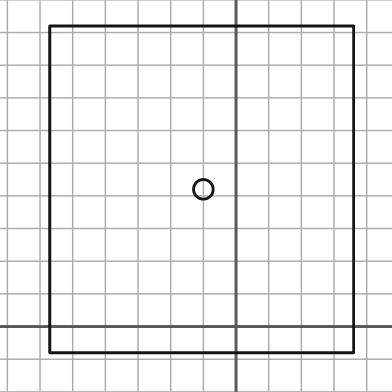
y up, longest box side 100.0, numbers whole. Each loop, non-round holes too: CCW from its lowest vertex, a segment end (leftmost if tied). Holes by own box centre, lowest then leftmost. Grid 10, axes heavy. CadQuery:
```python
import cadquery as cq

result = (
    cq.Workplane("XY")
    .moveTo(-57.0, -8.0)
    .lineTo(36.0, -8.0)
    .lineTo(36.0, 92.0)
    .lineTo(-57.0, 92.0)
    .close()
    .moveTo(-10.0, 42.0)
    .circle(3.0)
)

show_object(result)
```